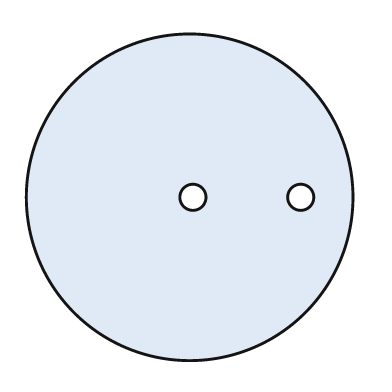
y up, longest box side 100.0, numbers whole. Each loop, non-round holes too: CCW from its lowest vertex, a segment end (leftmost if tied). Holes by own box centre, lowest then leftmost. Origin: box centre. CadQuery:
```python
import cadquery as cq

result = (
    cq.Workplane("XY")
    .moveTo(0.0, 0.0)
    .circle(50.0)
    .moveTo(1.0, 0.0)
    .circle(4.0)
    .moveTo(34.0, 0.0)
    .circle(4.0)
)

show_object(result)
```